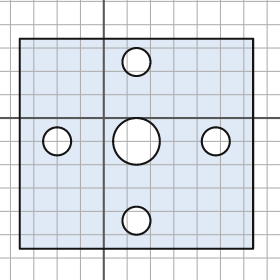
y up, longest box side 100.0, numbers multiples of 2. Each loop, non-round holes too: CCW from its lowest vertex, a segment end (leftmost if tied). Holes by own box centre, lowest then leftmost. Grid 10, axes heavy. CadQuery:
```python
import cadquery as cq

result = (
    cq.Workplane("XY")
    .moveTo(-36.0, -56.0)
    .lineTo(64.0, -56.0)
    .lineTo(64.0, 34.0)
    .lineTo(-36.0, 34.0)
    .close()
    .moveTo(14.0, -44.0)
    .circle(6.0)
    .moveTo(-20.0, -10.0)
    .circle(6.0)
    .moveTo(14.0, -10.0)
    .circle(10.0)
    .moveTo(48.0, -10.0)
    .circle(6.0)
    .moveTo(14.0, 24.0)
    .circle(6.0)
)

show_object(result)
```